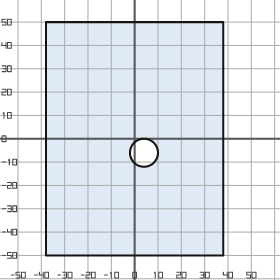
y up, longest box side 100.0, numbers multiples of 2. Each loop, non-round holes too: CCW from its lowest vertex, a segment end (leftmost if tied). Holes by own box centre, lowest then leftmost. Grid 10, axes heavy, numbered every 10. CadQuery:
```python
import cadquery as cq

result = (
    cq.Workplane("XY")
    .moveTo(-38.0, -50.0)
    .lineTo(38.0, -50.0)
    .lineTo(38.0, 50.0)
    .lineTo(-38.0, 50.0)
    .close()
    .moveTo(4.0, -6.0)
    .circle(6.0)
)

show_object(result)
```